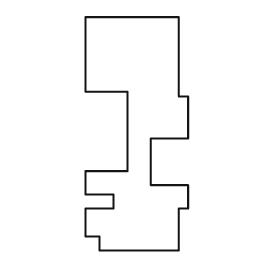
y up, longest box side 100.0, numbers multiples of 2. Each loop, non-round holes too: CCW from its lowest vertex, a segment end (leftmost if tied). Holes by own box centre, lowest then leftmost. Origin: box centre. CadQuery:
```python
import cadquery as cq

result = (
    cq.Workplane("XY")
    .moveTo(-16.0, -50.0)
    .lineTo(18.0, -50.0)
    .lineTo(18.0, -32.0)
    .lineTo(22.0, -32.0)
    .lineTo(22.0, -22.0)
    .lineTo(6.0, -22.0)
    .lineTo(6.0, -2.0)
    .lineTo(22.0, -2.0)
    .lineTo(22.0, 16.0)
    .lineTo(18.0, 16.0)
    .lineTo(18.0, 50.0)
    .lineTo(-22.0, 50.0)
    .lineTo(-22.0, 18.0)
    .lineTo(-4.0, 18.0)
    .lineTo(-4.0, -16.0)
    .lineTo(-22.0, -16.0)
    .lineTo(-22.0, -26.0)
    .lineTo(-10.0, -26.0)
    .lineTo(-10.0, -32.0)
    .lineTo(-22.0, -32.0)
    .lineTo(-22.0, -44.0)
    .lineTo(-16.0, -44.0)
    .close()
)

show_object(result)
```